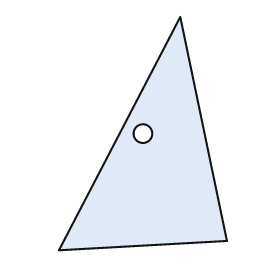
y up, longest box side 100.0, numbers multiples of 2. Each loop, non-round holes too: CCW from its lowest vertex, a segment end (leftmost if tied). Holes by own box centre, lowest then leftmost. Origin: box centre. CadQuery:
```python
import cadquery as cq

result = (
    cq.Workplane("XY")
    .moveTo(-36.0, -50.0)
    .lineTo(36.0, -46.0)
    .lineTo(16.0, 50.0)
    .close()
    .moveTo(0.0, 0.0)
    .circle(4.0)
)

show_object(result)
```